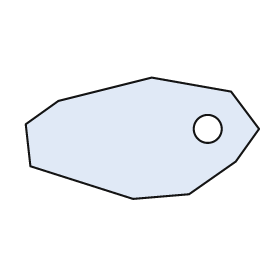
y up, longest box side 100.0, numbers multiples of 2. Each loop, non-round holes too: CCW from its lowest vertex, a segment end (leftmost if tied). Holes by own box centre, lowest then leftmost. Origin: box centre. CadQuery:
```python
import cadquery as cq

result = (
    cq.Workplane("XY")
    .moveTo(-4.0, -26.0)
    .lineTo(20.0, -24.0)
    .lineTo(40.0, -10.0)
    .lineTo(50.0, 4.0)
    .lineTo(38.0, 20.0)
    .lineTo(4.0, 26.0)
    .lineTo(-36.0, 16.0)
    .lineTo(-50.0, 6.0)
    .lineTo(-48.0, -12.0)
    .close()
    .moveTo(28.0, 4.0)
    .circle(6.0)
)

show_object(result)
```